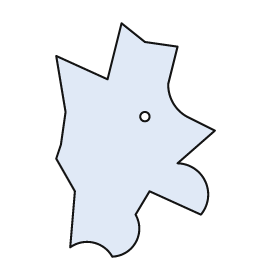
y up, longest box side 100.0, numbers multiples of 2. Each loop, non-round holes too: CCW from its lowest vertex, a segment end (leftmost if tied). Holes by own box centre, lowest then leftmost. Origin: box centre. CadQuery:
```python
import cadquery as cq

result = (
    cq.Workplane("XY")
    .moveTo(-10.0, -50.0)
    .threePointArc((0.0, -44.0), (0.0, -32.0))
    .lineTo(6.0, -22.0)
    .lineTo(28.0, -32.0)
    .threePointArc((30.0, -18.0), (18.0, -10.0))
    .lineTo(34.0, 4.0)
    .lineTo(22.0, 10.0)
    .threePointArc((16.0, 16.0), (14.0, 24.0))
    .lineTo(18.0, 40.0)
    .lineTo(4.0, 42.0)
    .lineTo(-6.0, 50.0)
    .lineTo(-12.0, 26.0)
    .lineTo(-34.0, 36.0)
    .lineTo(-30.0, 12.0)
    .lineTo(-32.0, -2.0)
    .lineTo(-34.0, -8.0)
    .lineTo(-26.0, -22.0)
    .lineTo(-28.0, -46.0)
    .threePointArc((-18.0, -44.0), (-10.0, -50.0))
    .close()
    .moveTo(4.0, 10.0)
    .circle(2.0)
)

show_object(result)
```